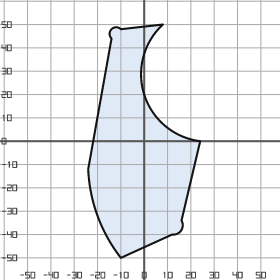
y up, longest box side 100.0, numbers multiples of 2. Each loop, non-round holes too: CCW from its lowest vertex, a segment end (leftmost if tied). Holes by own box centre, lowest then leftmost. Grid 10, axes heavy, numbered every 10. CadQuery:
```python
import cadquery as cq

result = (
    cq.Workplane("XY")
    .moveTo(-10.0, -50.0)
    .lineTo(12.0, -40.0)
    .threePointArc((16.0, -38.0), (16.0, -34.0))
    .lineTo(24.0, 0.0)
    .threePointArc((0.0, 20.0), (8.0, 50.0))
    .lineTo(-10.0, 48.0)
    .threePointArc((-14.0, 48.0), (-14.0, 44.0))
    .lineTo(-24.0, -12.0)
    .threePointArc((-20.0, -32.0), (-10.0, -50.0))
    .close()
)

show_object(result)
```